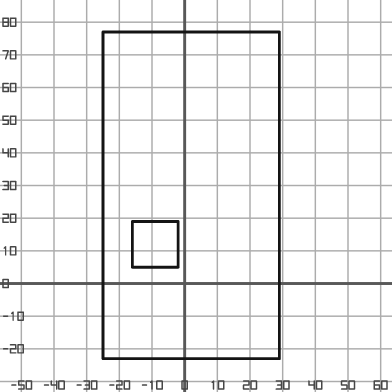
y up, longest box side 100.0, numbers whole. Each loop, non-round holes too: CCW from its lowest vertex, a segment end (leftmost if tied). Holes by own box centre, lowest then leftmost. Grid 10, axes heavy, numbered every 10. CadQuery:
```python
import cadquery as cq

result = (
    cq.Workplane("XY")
    .moveTo(-25.0, -23.0)
    .lineTo(29.0, -23.0)
    .lineTo(29.0, 77.0)
    .lineTo(-25.0, 77.0)
    .close()
    .moveTo(-16.0, 5.0)
    .lineTo(-2.0, 5.0)
    .lineTo(-2.0, 19.0)
    .lineTo(-16.0, 19.0)
    .close()
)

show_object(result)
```